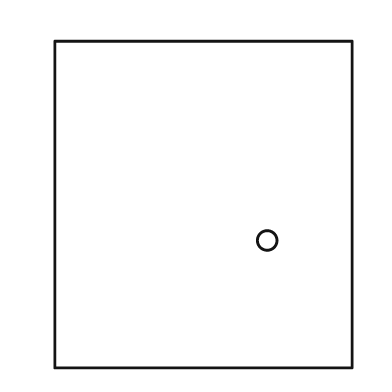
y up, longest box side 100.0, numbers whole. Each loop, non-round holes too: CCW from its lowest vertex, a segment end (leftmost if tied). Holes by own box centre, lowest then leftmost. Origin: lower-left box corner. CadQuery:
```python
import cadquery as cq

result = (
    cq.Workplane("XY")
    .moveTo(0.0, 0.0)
    .lineTo(91.0, 0.0)
    .lineTo(91.0, 100.0)
    .lineTo(0.0, 100.0)
    .close()
    .moveTo(65.0, 39.0)
    .circle(3.0)
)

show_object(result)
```